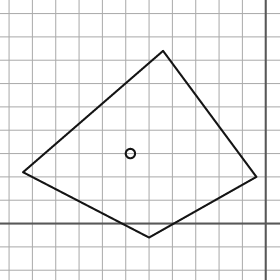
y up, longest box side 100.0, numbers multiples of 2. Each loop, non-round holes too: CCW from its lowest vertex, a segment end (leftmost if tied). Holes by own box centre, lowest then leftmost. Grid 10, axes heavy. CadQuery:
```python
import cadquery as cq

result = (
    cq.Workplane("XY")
    .moveTo(-50.0, -6.0)
    .lineTo(-4.0, 20.0)
    .lineTo(-44.0, 74.0)
    .lineTo(-104.0, 22.0)
    .close()
    .moveTo(-58.0, 30.0)
    .circle(2.0)
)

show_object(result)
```